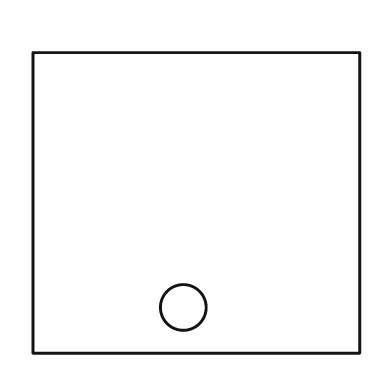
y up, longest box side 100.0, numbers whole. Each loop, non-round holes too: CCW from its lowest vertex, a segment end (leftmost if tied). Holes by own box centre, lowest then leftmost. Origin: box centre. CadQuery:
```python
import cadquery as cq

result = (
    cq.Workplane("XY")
    .moveTo(-50.0, -46.0)
    .lineTo(50.0, -46.0)
    .lineTo(50.0, 46.0)
    .lineTo(-50.0, 46.0)
    .close()
    .moveTo(-4.0, -32.0)
    .circle(7.0)
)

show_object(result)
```